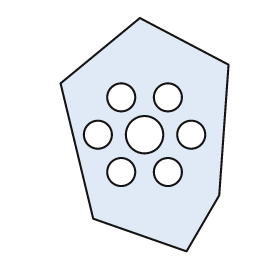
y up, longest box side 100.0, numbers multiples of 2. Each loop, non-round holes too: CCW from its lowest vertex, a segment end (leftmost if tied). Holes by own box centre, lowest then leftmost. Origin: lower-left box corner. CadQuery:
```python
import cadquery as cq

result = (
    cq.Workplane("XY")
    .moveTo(54.0, 0.0)
    .lineTo(68.0, 24.0)
    .lineTo(72.0, 80.0)
    .lineTo(34.0, 100.0)
    .lineTo(0.0, 72.0)
    .lineTo(14.0, 14.0)
    .close()
    .moveTo(26.0, 34.0)
    .circle(6.0)
    .moveTo(46.0, 34.0)
    .circle(6.0)
    .moveTo(16.0, 50.0)
    .circle(6.0)
    .moveTo(36.0, 50.0)
    .circle(8.0)
    .moveTo(56.0, 50.0)
    .circle(6.0)
    .moveTo(26.0, 66.0)
    .circle(6.0)
    .moveTo(46.0, 66.0)
    .circle(6.0)
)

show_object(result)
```